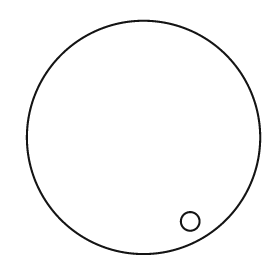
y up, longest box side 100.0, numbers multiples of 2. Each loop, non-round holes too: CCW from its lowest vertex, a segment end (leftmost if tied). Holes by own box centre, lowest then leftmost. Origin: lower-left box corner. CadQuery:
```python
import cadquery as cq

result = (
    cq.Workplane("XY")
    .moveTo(50.0, 50.0)
    .circle(50.0)
    .moveTo(70.0, 14.0)
    .circle(4.0)
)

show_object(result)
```